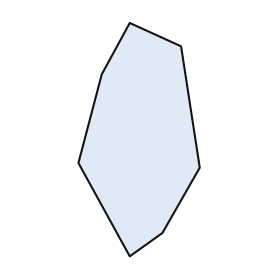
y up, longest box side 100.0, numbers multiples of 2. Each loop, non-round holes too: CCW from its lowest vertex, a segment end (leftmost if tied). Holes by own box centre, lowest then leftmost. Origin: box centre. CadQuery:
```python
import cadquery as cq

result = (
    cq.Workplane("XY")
    .moveTo(-4.0, -50.0)
    .lineTo(10.0, -40.0)
    .lineTo(26.0, -12.0)
    .lineTo(18.0, 40.0)
    .lineTo(-4.0, 50.0)
    .lineTo(-16.0, 28.0)
    .lineTo(-26.0, -10.0)
    .close()
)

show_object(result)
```